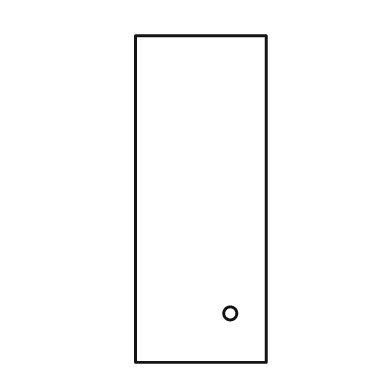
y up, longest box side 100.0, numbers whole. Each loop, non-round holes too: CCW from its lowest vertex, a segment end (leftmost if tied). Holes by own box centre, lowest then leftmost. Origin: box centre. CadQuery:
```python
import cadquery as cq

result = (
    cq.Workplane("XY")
    .moveTo(-20.0, -50.0)
    .lineTo(20.0, -50.0)
    .lineTo(20.0, 50.0)
    .lineTo(-20.0, 50.0)
    .close()
    .moveTo(9.0, -35.0)
    .circle(2.0)
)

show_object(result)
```